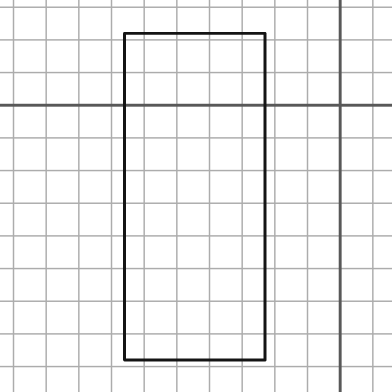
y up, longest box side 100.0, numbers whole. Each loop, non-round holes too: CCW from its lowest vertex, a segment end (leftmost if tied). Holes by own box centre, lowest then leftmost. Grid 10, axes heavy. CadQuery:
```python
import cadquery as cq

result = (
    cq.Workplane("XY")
    .moveTo(-66.0, -78.0)
    .lineTo(-23.0, -78.0)
    .lineTo(-23.0, 22.0)
    .lineTo(-66.0, 22.0)
    .close()
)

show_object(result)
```